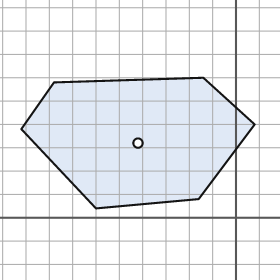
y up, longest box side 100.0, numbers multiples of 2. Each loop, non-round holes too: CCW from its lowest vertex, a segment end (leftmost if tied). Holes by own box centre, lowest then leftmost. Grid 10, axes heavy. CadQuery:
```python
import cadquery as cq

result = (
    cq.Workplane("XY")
    .moveTo(-60.0, 4.0)
    .lineTo(-16.0, 8.0)
    .lineTo(8.0, 40.0)
    .lineTo(-14.0, 60.0)
    .lineTo(-78.0, 58.0)
    .lineTo(-92.0, 38.0)
    .close()
    .moveTo(-42.0, 32.0)
    .circle(2.0)
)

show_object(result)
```